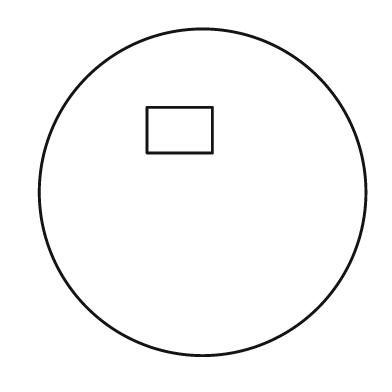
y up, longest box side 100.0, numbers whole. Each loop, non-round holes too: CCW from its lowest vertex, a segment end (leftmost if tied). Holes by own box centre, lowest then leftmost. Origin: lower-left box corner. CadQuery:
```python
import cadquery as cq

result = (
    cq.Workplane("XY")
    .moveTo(50.0, 50.0)
    .circle(50.0)
    .moveTo(33.0, 62.0)
    .lineTo(53.0, 62.0)
    .lineTo(53.0, 76.0)
    .lineTo(33.0, 76.0)
    .close()
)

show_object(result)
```